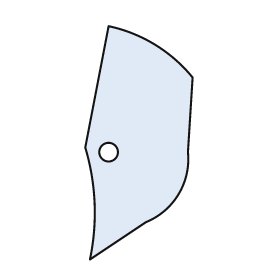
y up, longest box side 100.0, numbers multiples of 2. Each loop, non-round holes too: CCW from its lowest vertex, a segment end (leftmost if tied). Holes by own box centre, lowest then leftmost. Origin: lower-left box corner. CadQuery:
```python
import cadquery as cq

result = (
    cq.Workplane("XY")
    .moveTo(2.0, 0.0)
    .lineTo(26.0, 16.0)
    .threePointArc((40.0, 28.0), (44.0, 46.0))
    .lineTo(46.0, 78.0)
    .threePointArc((30.0, 92.0), (10.0, 100.0))
    .lineTo(0.0, 48.0)
    .threePointArc((4.0, 24.0), (2.0, 0.0))
    .close()
    .moveTo(10.0, 46.0)
    .circle(4.0)
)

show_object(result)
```